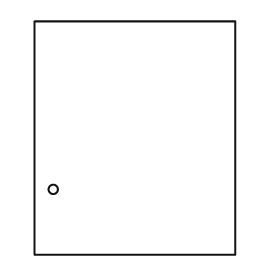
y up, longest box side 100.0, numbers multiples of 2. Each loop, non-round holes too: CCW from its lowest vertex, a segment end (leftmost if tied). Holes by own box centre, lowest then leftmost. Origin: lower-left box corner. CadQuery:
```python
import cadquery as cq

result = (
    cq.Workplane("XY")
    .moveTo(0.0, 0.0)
    .lineTo(86.0, 0.0)
    .lineTo(86.0, 100.0)
    .lineTo(0.0, 100.0)
    .close()
    .moveTo(8.0, 28.0)
    .circle(2.0)
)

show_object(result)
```